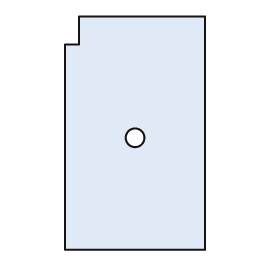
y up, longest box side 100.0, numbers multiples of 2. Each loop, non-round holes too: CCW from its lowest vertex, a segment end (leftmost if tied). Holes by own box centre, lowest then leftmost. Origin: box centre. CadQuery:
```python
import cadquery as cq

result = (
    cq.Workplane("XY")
    .moveTo(-30.0, -50.0)
    .lineTo(30.0, -50.0)
    .lineTo(30.0, 50.0)
    .lineTo(-24.0, 50.0)
    .lineTo(-24.0, 38.0)
    .lineTo(-30.0, 38.0)
    .close()
    .moveTo(0.0, -2.0)
    .circle(4.0)
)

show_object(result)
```